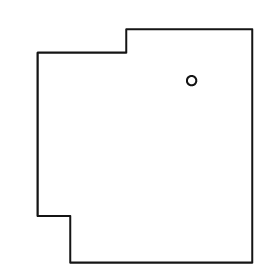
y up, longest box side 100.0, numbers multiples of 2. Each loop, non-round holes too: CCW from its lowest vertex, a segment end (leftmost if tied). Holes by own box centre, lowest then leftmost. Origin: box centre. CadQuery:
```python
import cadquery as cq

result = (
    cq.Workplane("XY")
    .moveTo(-32.0, -50.0)
    .lineTo(46.0, -50.0)
    .lineTo(46.0, 50.0)
    .lineTo(-8.0, 50.0)
    .lineTo(-8.0, 40.0)
    .lineTo(-46.0, 40.0)
    .lineTo(-46.0, -30.0)
    .lineTo(-32.0, -30.0)
    .close()
    .moveTo(20.0, 28.0)
    .circle(2.0)
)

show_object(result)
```